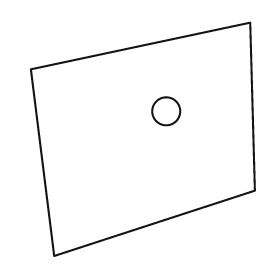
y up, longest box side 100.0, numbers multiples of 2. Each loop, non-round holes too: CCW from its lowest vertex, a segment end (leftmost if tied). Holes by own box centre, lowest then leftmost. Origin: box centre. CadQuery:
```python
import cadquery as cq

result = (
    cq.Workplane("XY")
    .moveTo(-38.0, -50.0)
    .lineTo(48.0, -22.0)
    .lineTo(46.0, 50.0)
    .lineTo(-48.0, 30.0)
    .close()
    .moveTo(10.0, 12.0)
    .circle(6.0)
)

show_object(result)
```